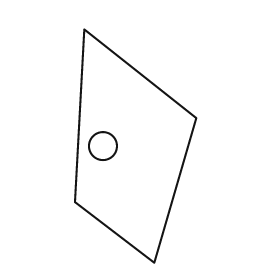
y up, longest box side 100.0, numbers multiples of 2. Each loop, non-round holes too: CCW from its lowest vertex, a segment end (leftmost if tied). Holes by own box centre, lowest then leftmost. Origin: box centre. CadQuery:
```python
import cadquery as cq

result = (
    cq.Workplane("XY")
    .moveTo(8.0, -50.0)
    .lineTo(26.0, 12.0)
    .lineTo(-22.0, 50.0)
    .lineTo(-26.0, -24.0)
    .close()
    .moveTo(-14.0, 0.0)
    .circle(6.0)
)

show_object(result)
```